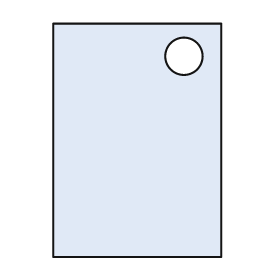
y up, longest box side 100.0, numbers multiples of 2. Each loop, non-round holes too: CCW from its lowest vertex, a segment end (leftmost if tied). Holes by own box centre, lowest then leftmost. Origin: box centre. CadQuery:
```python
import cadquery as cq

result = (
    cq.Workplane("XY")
    .moveTo(-36.0, -50.0)
    .lineTo(36.0, -50.0)
    .lineTo(36.0, 50.0)
    .lineTo(-36.0, 50.0)
    .close()
    .moveTo(20.0, 36.0)
    .circle(8.0)
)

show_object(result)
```